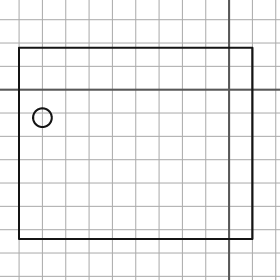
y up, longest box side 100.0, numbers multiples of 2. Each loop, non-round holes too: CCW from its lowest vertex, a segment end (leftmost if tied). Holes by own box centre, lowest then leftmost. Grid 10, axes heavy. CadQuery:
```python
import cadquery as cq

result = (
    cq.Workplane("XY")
    .moveTo(-90.0, -64.0)
    .lineTo(10.0, -64.0)
    .lineTo(10.0, 18.0)
    .lineTo(-90.0, 18.0)
    .close()
    .moveTo(-80.0, -12.0)
    .circle(4.0)
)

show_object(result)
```